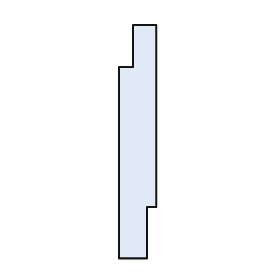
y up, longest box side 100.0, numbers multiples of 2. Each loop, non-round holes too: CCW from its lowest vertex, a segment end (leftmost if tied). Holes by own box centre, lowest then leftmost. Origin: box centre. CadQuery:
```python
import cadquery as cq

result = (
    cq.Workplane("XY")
    .moveTo(-8.0, -50.0)
    .lineTo(4.0, -50.0)
    .lineTo(4.0, -28.0)
    .lineTo(8.0, -28.0)
    .lineTo(8.0, 50.0)
    .lineTo(-2.0, 50.0)
    .lineTo(-2.0, 32.0)
    .lineTo(-8.0, 32.0)
    .close()
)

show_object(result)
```